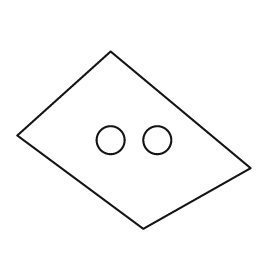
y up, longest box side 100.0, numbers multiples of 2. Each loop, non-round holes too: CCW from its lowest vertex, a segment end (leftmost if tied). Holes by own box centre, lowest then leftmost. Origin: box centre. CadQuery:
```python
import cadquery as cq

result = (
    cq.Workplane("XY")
    .moveTo(4.0, -38.0)
    .lineTo(50.0, -12.0)
    .lineTo(-10.0, 38.0)
    .lineTo(-50.0, 2.0)
    .close()
    .moveTo(-10.0, 0.0)
    .circle(6.0)
    .moveTo(10.0, 0.0)
    .circle(6.0)
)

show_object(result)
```